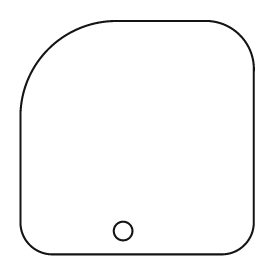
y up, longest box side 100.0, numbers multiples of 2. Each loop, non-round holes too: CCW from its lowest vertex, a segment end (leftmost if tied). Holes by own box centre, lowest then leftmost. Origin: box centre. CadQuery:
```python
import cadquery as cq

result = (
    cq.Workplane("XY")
    .moveTo(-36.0, -50.0)
    .lineTo(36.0, -50.0)
    .threePointArc((46.0, -46.0), (50.0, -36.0))
    .lineTo(50.0, 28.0)
    .threePointArc((44.0, 44.0), (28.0, 50.0))
    .lineTo(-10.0, 50.0)
    .threePointArc((-38.0, 38.0), (-50.0, 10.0))
    .lineTo(-50.0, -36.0)
    .threePointArc((-46.0, -46.0), (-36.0, -50.0))
    .close()
    .moveTo(-6.0, -40.0)
    .circle(4.0)
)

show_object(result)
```